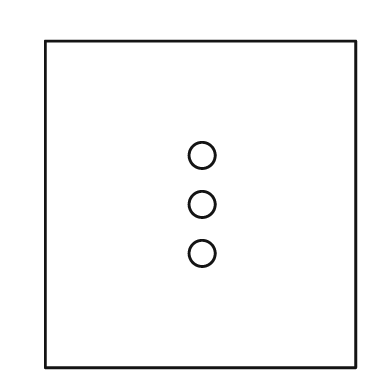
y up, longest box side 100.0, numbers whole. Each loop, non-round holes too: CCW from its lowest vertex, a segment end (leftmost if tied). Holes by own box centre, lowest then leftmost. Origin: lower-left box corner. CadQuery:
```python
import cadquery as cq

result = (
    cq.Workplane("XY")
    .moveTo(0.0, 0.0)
    .lineTo(95.0, 0.0)
    .lineTo(95.0, 100.0)
    .lineTo(0.0, 100.0)
    .close()
    .moveTo(48.0, 35.0)
    .circle(4.0)
    .moveTo(48.0, 50.0)
    .circle(4.0)
    .moveTo(48.0, 65.0)
    .circle(4.0)
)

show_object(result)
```